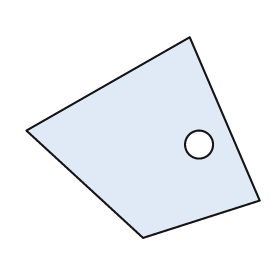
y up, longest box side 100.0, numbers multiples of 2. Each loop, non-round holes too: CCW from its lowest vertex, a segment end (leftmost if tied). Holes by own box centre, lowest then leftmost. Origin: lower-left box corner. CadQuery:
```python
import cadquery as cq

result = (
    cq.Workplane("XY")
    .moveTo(50.0, 0.0)
    .lineTo(100.0, 16.0)
    .lineTo(70.0, 86.0)
    .lineTo(0.0, 46.0)
    .close()
    .moveTo(74.0, 40.0)
    .circle(6.0)
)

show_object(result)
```